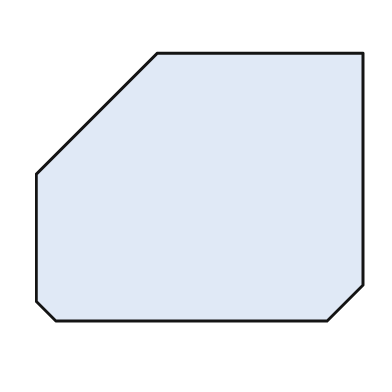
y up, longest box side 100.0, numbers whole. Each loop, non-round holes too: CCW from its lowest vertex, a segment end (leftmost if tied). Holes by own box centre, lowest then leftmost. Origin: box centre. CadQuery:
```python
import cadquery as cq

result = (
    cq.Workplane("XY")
    .moveTo(-44.0, -41.0)
    .lineTo(39.0, -41.0)
    .lineTo(50.0, -30.0)
    .lineTo(50.0, 41.0)
    .lineTo(-13.0, 41.0)
    .lineTo(-50.0, 4.0)
    .lineTo(-50.0, -35.0)
    .close()
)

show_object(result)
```